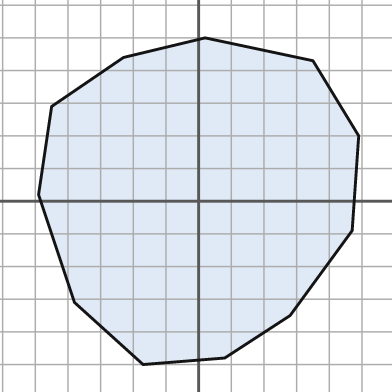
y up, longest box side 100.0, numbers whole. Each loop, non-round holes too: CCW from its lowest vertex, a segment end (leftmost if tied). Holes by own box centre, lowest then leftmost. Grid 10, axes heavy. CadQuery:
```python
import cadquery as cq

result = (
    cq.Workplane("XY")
    .moveTo(-17.0, -50.0)
    .lineTo(8.0, -48.0)
    .lineTo(28.0, -35.0)
    .lineTo(47.0, -9.0)
    .lineTo(49.0, 20.0)
    .lineTo(35.0, 43.0)
    .lineTo(2.0, 50.0)
    .lineTo(-23.0, 44.0)
    .lineTo(-45.0, 29.0)
    .lineTo(-49.0, 2.0)
    .lineTo(-38.0, -31.0)
    .close()
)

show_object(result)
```